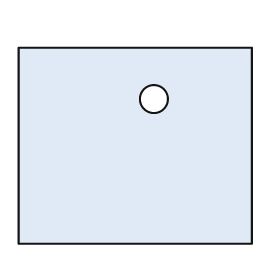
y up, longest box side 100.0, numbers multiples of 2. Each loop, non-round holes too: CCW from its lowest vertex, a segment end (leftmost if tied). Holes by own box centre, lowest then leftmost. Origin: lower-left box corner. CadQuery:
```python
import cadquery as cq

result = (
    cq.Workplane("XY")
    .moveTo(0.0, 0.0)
    .lineTo(100.0, 0.0)
    .lineTo(100.0, 84.0)
    .lineTo(0.0, 84.0)
    .close()
    .moveTo(58.0, 62.0)
    .circle(6.0)
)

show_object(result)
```